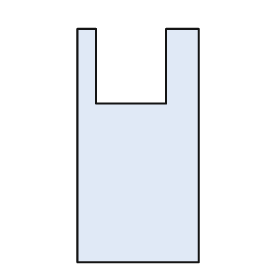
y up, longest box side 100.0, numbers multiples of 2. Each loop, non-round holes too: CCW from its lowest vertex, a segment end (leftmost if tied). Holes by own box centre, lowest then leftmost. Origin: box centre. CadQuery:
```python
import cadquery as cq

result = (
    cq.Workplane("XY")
    .moveTo(-26.0, -50.0)
    .lineTo(26.0, -50.0)
    .lineTo(26.0, 50.0)
    .lineTo(12.0, 50.0)
    .lineTo(12.0, 18.0)
    .lineTo(-18.0, 18.0)
    .lineTo(-18.0, 50.0)
    .lineTo(-26.0, 50.0)
    .close()
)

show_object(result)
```